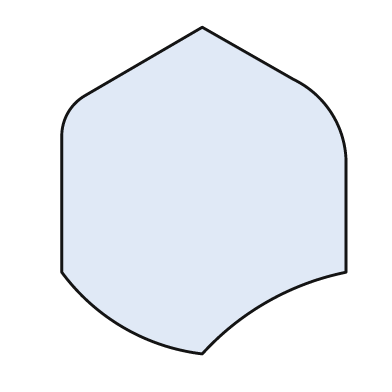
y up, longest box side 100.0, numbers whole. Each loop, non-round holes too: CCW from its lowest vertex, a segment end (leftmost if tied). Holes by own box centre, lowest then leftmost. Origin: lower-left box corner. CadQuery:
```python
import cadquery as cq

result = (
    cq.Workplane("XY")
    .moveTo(43.0, 0.0)
    .threePointArc((63.0, 16.0), (87.0, 25.0))
    .lineTo(87.0, 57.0)
    .threePointArc((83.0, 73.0), (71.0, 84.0))
    .lineTo(43.0, 100.0)
    .lineTo(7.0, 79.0)
    .threePointArc((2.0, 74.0), (0.0, 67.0))
    .lineTo(0.0, 25.0)
    .threePointArc((19.0, 8.0), (43.0, 0.0))
    .close()
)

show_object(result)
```